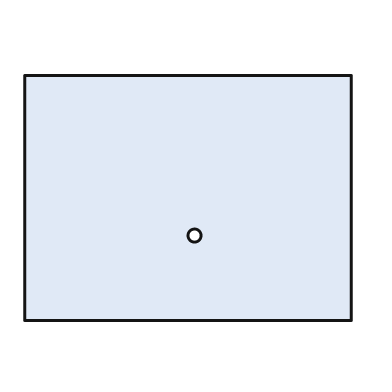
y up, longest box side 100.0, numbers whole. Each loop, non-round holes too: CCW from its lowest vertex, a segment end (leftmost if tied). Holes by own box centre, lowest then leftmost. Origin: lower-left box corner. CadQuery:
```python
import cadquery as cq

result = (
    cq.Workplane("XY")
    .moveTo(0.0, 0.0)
    .lineTo(100.0, 0.0)
    .lineTo(100.0, 75.0)
    .lineTo(0.0, 75.0)
    .close()
    .moveTo(52.0, 26.0)
    .circle(2.0)
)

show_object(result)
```